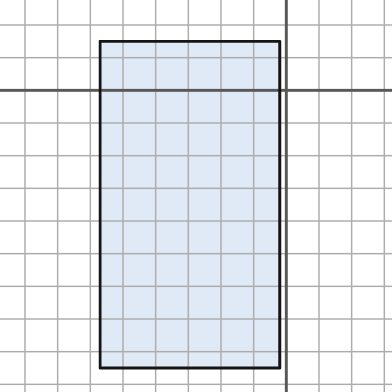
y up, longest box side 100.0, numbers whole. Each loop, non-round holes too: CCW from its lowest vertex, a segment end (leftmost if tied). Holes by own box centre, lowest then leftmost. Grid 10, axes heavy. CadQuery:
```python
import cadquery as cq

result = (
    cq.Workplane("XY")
    .moveTo(-57.0, -85.0)
    .lineTo(-2.0, -85.0)
    .lineTo(-2.0, 15.0)
    .lineTo(-57.0, 15.0)
    .close()
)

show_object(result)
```